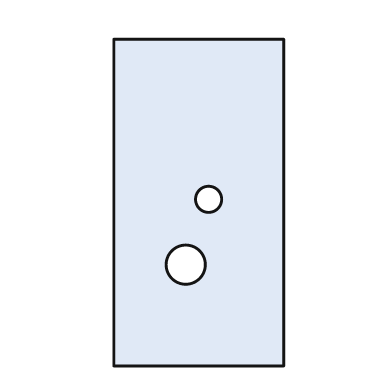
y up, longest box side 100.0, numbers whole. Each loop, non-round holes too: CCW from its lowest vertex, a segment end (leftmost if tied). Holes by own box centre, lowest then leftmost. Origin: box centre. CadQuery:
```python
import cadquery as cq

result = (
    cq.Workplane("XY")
    .moveTo(-26.0, -50.0)
    .lineTo(26.0, -50.0)
    .lineTo(26.0, 50.0)
    .lineTo(-26.0, 50.0)
    .close()
    .moveTo(-4.0, -19.0)
    .circle(6.0)
    .moveTo(3.0, 1.0)
    .circle(4.0)
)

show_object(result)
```